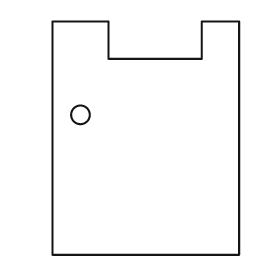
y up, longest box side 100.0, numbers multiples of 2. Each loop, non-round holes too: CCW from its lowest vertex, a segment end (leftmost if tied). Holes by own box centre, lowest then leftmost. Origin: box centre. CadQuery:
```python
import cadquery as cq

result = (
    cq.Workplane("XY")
    .moveTo(-40.0, -50.0)
    .lineTo(40.0, -50.0)
    .lineTo(40.0, 50.0)
    .lineTo(24.0, 50.0)
    .lineTo(24.0, 34.0)
    .lineTo(-16.0, 34.0)
    .lineTo(-16.0, 50.0)
    .lineTo(-40.0, 50.0)
    .close()
    .moveTo(-28.0, 10.0)
    .circle(4.0)
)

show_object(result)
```